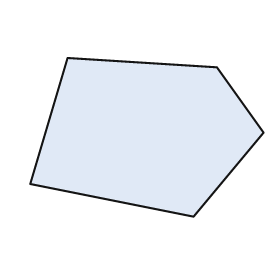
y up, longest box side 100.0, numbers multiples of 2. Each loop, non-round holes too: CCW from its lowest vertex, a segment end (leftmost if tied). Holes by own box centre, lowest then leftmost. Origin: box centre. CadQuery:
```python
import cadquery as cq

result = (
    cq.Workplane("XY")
    .moveTo(20.0, -34.0)
    .lineTo(50.0, 2.0)
    .lineTo(30.0, 30.0)
    .lineTo(-34.0, 34.0)
    .lineTo(-50.0, -20.0)
    .close()
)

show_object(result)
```